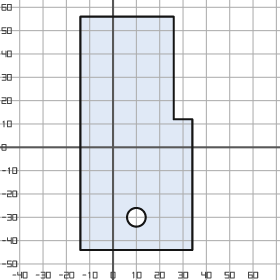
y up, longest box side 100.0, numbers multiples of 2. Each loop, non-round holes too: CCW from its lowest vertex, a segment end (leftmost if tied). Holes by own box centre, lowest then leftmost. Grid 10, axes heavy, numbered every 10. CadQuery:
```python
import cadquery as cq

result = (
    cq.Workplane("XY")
    .moveTo(-14.0, -44.0)
    .lineTo(34.0, -44.0)
    .lineTo(34.0, 12.0)
    .lineTo(26.0, 12.0)
    .lineTo(26.0, 56.0)
    .lineTo(-14.0, 56.0)
    .close()
    .moveTo(10.0, -30.0)
    .circle(4.0)
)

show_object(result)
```